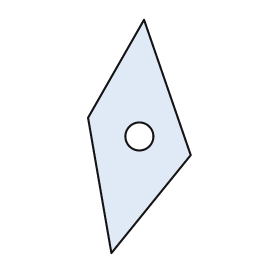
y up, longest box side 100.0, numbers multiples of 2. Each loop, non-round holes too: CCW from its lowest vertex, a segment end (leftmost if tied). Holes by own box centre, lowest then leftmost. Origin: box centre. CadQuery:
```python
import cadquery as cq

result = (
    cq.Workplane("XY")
    .moveTo(-12.0, -50.0)
    .lineTo(22.0, -8.0)
    .lineTo(2.0, 50.0)
    .lineTo(-22.0, 8.0)
    .close()
    .moveTo(0.0, 0.0)
    .circle(6.0)
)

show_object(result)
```